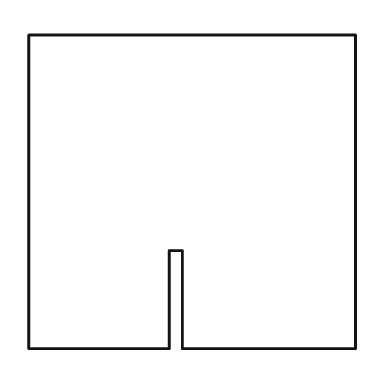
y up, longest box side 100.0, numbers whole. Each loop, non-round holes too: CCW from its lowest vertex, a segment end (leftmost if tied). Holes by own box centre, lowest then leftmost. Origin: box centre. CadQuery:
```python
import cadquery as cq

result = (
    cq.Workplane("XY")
    .moveTo(-50.0, -48.0)
    .lineTo(-7.0, -48.0)
    .lineTo(-7.0, -18.0)
    .lineTo(-3.0, -18.0)
    .lineTo(-3.0, -48.0)
    .lineTo(50.0, -48.0)
    .lineTo(50.0, 48.0)
    .lineTo(-50.0, 48.0)
    .close()
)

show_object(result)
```